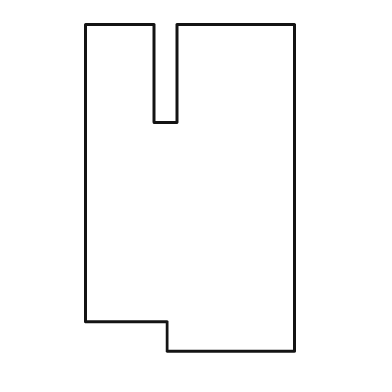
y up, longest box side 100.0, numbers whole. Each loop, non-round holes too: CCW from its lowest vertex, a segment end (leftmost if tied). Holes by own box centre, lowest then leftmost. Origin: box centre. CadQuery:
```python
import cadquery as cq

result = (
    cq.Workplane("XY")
    .moveTo(-7.0, -50.0)
    .lineTo(32.0, -50.0)
    .lineTo(32.0, 50.0)
    .lineTo(-4.0, 50.0)
    .lineTo(-4.0, 20.0)
    .lineTo(-11.0, 20.0)
    .lineTo(-11.0, 50.0)
    .lineTo(-32.0, 50.0)
    .lineTo(-32.0, -41.0)
    .lineTo(-7.0, -41.0)
    .close()
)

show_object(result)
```